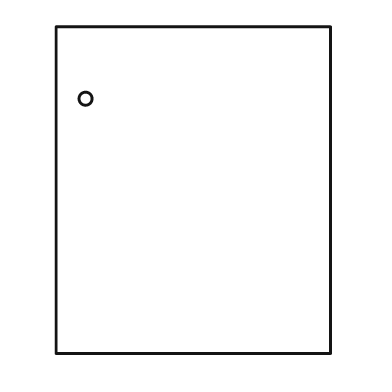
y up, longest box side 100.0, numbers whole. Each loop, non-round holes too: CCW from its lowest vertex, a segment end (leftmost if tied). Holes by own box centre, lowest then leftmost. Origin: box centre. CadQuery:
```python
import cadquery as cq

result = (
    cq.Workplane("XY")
    .moveTo(-42.0, -50.0)
    .lineTo(42.0, -50.0)
    .lineTo(42.0, 50.0)
    .lineTo(-42.0, 50.0)
    .close()
    .moveTo(-33.0, 28.0)
    .circle(2.0)
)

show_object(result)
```